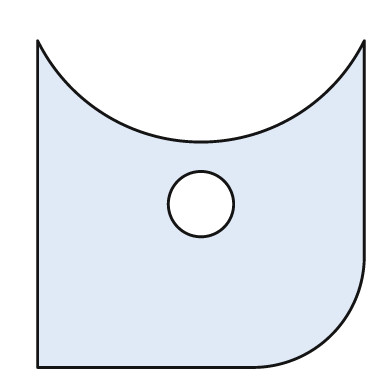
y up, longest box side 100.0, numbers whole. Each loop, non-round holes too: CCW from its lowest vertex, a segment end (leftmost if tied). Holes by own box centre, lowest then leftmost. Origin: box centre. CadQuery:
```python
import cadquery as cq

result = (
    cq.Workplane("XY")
    .moveTo(-50.0, -50.0)
    .lineTo(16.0, -50.0)
    .threePointArc((40.0, -40.0), (50.0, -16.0))
    .lineTo(50.0, 50.0)
    .threePointArc((0.0, 19.0), (-50.0, 50.0))
    .close()
    .moveTo(0.0, 0.0)
    .circle(10.0)
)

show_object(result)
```